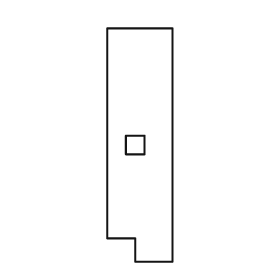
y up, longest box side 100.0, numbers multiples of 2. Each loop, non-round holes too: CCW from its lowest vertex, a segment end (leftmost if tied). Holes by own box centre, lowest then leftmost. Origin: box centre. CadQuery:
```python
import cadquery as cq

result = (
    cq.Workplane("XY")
    .moveTo(-2.0, -50.0)
    .lineTo(14.0, -50.0)
    .lineTo(14.0, 50.0)
    .lineTo(-14.0, 50.0)
    .lineTo(-14.0, -40.0)
    .lineTo(-2.0, -40.0)
    .close()
    .moveTo(-6.0, -4.0)
    .lineTo(2.0, -4.0)
    .lineTo(2.0, 4.0)
    .lineTo(-6.0, 4.0)
    .close()
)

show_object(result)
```